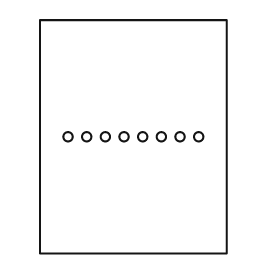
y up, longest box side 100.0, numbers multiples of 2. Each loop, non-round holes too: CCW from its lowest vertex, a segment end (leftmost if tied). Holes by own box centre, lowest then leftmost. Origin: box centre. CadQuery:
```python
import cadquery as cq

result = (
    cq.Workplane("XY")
    .moveTo(-40.0, -50.0)
    .lineTo(40.0, -50.0)
    .lineTo(40.0, 50.0)
    .lineTo(-40.0, 50.0)
    .close()
    .moveTo(-28.0, 0.0)
    .circle(2.0)
    .moveTo(-20.0, 0.0)
    .circle(2.0)
    .moveTo(-12.0, 0.0)
    .circle(2.0)
    .moveTo(-4.0, 0.0)
    .circle(2.0)
    .moveTo(4.0, 0.0)
    .circle(2.0)
    .moveTo(12.0, 0.0)
    .circle(2.0)
    .moveTo(20.0, 0.0)
    .circle(2.0)
    .moveTo(28.0, 0.0)
    .circle(2.0)
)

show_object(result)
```